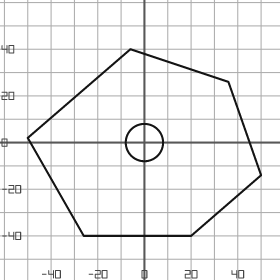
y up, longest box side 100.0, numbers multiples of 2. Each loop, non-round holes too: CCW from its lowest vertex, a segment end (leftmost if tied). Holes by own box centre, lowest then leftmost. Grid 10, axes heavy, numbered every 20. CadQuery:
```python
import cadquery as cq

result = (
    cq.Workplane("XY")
    .moveTo(-26.0, -40.0)
    .lineTo(20.0, -40.0)
    .lineTo(50.0, -14.0)
    .lineTo(36.0, 26.0)
    .lineTo(-6.0, 40.0)
    .lineTo(-50.0, 2.0)
    .close()
    .moveTo(0.0, 0.0)
    .circle(8.0)
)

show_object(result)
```